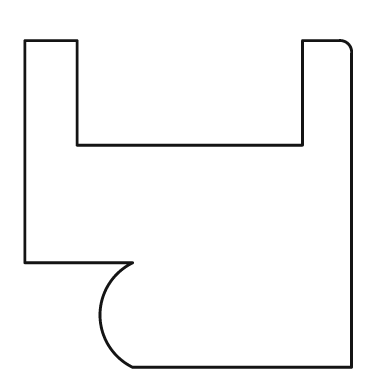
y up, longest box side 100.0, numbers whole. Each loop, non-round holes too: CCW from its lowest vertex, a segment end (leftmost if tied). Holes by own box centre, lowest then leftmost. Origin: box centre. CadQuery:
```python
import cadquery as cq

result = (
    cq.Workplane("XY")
    .moveTo(-17.0, -50.0)
    .lineTo(50.0, -50.0)
    .lineTo(50.0, 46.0)
    .threePointArc((49.0, 49.0), (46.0, 50.0))
    .lineTo(35.0, 50.0)
    .lineTo(35.0, 18.0)
    .lineTo(-34.0, 18.0)
    .lineTo(-34.0, 50.0)
    .lineTo(-50.0, 50.0)
    .lineTo(-50.0, -18.0)
    .lineTo(-17.0, -18.0)
    .threePointArc((-27.0, -34.0), (-17.0, -50.0))
    .close()
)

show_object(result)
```